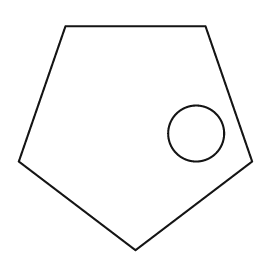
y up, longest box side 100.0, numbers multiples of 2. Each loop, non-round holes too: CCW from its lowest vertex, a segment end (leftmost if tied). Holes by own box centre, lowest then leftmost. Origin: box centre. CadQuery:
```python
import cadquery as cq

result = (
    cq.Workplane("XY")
    .moveTo(0.0, -48.0)
    .lineTo(50.0, -10.0)
    .lineTo(30.0, 48.0)
    .lineTo(-30.0, 48.0)
    .lineTo(-50.0, -10.0)
    .close()
    .moveTo(26.0, 2.0)
    .circle(12.0)
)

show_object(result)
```